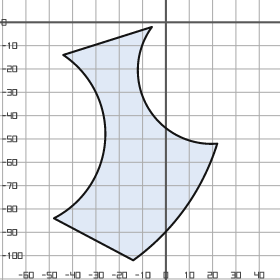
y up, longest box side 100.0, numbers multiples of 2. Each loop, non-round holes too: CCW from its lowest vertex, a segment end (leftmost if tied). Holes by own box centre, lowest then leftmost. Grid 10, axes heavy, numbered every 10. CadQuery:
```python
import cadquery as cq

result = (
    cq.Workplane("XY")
    .moveTo(-14.0, -102.0)
    .threePointArc((8.0, -80.0), (22.0, -52.0))
    .threePointArc((-8.0, -36.0), (-6.0, -2.0))
    .lineTo(-44.0, -14.0)
    .threePointArc((-26.0, -50.0), (-48.0, -84.0))
    .close()
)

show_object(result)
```